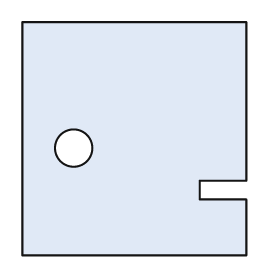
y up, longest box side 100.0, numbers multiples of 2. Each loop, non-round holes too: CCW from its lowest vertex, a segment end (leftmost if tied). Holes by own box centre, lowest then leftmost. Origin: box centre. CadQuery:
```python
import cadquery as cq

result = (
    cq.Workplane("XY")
    .moveTo(-48.0, -50.0)
    .lineTo(48.0, -50.0)
    .lineTo(48.0, -26.0)
    .lineTo(28.0, -26.0)
    .lineTo(28.0, -18.0)
    .lineTo(48.0, -18.0)
    .lineTo(48.0, 50.0)
    .lineTo(-48.0, 50.0)
    .close()
    .moveTo(-26.0, -4.0)
    .circle(8.0)
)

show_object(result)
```